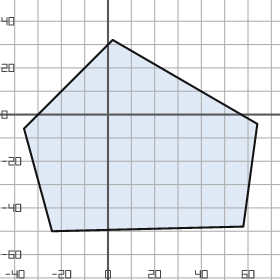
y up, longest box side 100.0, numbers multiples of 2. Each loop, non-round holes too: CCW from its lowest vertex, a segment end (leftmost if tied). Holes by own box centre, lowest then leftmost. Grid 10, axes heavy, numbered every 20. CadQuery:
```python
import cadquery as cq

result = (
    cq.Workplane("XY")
    .moveTo(-24.0, -50.0)
    .lineTo(58.0, -48.0)
    .lineTo(64.0, -4.0)
    .lineTo(2.0, 32.0)
    .lineTo(-36.0, -6.0)
    .close()
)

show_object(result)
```